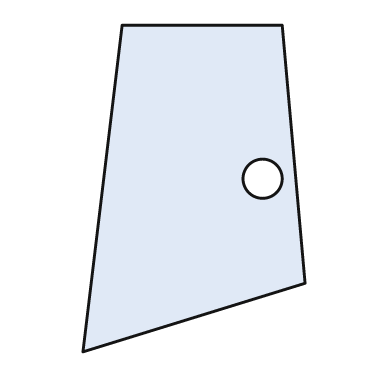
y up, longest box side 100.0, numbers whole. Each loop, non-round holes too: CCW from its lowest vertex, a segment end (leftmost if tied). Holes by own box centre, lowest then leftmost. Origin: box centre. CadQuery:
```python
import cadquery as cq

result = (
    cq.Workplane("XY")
    .moveTo(-34.0, -50.0)
    .lineTo(34.0, -29.0)
    .lineTo(27.0, 50.0)
    .lineTo(-22.0, 50.0)
    .close()
    .moveTo(21.0, 3.0)
    .circle(6.0)
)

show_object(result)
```